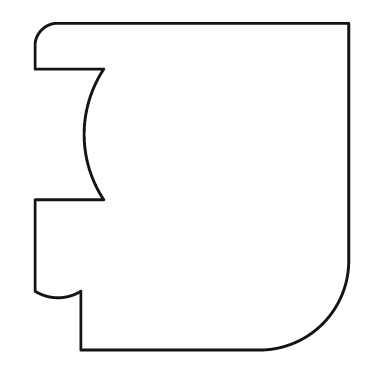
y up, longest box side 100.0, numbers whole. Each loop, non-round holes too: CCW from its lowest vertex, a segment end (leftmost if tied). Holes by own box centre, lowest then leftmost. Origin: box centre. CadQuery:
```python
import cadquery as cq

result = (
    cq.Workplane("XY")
    .moveTo(-34.0, -50.0)
    .lineTo(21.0, -50.0)
    .threePointArc((40.0, -42.0), (48.0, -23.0))
    .lineTo(48.0, 50.0)
    .lineTo(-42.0, 50.0)
    .threePointArc((-46.0, 48.0), (-48.0, 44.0))
    .lineTo(-48.0, 36.0)
    .lineTo(-27.0, 36.0)
    .threePointArc((-33.0, 16.0), (-27.0, -4.0))
    .lineTo(-48.0, -4.0)
    .lineTo(-48.0, -32.0)
    .threePointArc((-41.0, -34.0), (-34.0, -32.0))
    .close()
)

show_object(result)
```